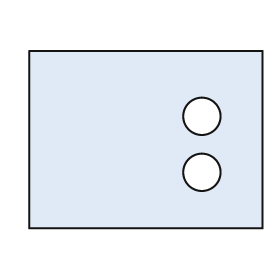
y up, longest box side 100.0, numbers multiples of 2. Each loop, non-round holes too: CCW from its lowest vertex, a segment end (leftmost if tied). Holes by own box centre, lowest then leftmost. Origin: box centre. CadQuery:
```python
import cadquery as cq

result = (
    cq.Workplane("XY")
    .moveTo(-50.0, -38.0)
    .lineTo(50.0, -38.0)
    .lineTo(50.0, 38.0)
    .lineTo(-50.0, 38.0)
    .close()
    .moveTo(24.0, -14.0)
    .circle(8.0)
    .moveTo(24.0, 10.0)
    .circle(8.0)
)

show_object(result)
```